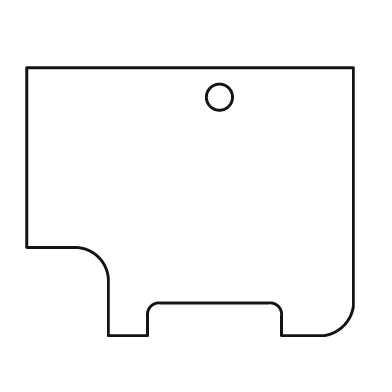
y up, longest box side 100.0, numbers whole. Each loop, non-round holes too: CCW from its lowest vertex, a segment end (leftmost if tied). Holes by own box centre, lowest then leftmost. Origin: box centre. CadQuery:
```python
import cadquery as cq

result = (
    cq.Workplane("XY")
    .moveTo(-25.0, -41.0)
    .lineTo(-13.0, -41.0)
    .lineTo(-13.0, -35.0)
    .threePointArc((-12.0, -32.0), (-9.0, -31.0))
    .lineTo(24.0, -31.0)
    .threePointArc((27.0, -32.0), (28.0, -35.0))
    .lineTo(28.0, -41.0)
    .lineTo(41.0, -41.0)
    .threePointArc((47.0, -38.0), (50.0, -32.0))
    .lineTo(50.0, 41.0)
    .lineTo(-50.0, 41.0)
    .lineTo(-50.0, -14.0)
    .lineTo(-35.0, -14.0)
    .threePointArc((-28.0, -17.0), (-25.0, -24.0))
    .close()
    .moveTo(9.0, 32.0)
    .circle(4.0)
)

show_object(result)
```